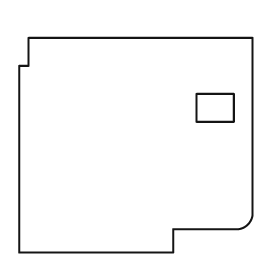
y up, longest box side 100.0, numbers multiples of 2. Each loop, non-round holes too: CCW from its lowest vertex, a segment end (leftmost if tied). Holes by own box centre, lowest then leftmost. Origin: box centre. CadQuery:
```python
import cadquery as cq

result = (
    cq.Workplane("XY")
    .moveTo(-50.0, -46.0)
    .lineTo(16.0, -46.0)
    .lineTo(16.0, -36.0)
    .lineTo(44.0, -36.0)
    .threePointArc((48.0, -34.0), (50.0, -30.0))
    .lineTo(50.0, 46.0)
    .lineTo(-46.0, 46.0)
    .lineTo(-46.0, 34.0)
    .lineTo(-50.0, 34.0)
    .close()
    .moveTo(26.0, 10.0)
    .lineTo(42.0, 10.0)
    .lineTo(42.0, 22.0)
    .lineTo(26.0, 22.0)
    .close()
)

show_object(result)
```